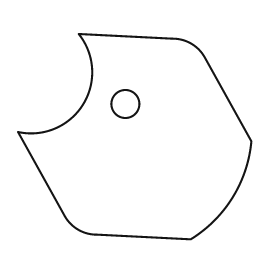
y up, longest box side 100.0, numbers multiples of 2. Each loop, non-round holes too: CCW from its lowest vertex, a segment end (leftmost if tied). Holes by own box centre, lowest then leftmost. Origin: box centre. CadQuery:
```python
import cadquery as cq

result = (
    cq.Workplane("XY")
    .moveTo(24.0, -44.0)
    .threePointArc((42.0, -26.0), (50.0, -2.0))
    .lineTo(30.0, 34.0)
    .threePointArc((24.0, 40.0), (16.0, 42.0))
    .lineTo(-24.0, 44.0)
    .threePointArc((-22.0, 14.0), (-50.0, 2.0))
    .lineTo(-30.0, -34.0)
    .threePointArc((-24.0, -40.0), (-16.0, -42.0))
    .close()
    .moveTo(-4.0, 14.0)
    .circle(6.0)
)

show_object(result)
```